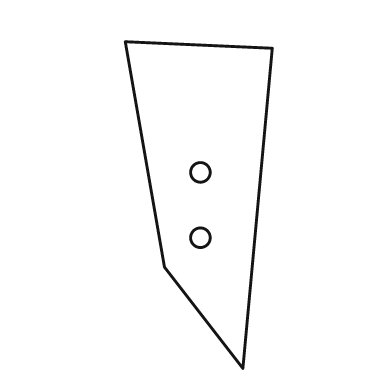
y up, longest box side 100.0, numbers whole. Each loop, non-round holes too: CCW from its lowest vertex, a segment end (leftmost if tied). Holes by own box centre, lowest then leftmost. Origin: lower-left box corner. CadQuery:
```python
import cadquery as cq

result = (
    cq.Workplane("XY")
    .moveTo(36.0, 0.0)
    .lineTo(45.0, 98.0)
    .lineTo(0.0, 100.0)
    .lineTo(12.0, 31.0)
    .close()
    .moveTo(23.0, 40.0)
    .circle(3.0)
    .moveTo(23.0, 60.0)
    .circle(3.0)
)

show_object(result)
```